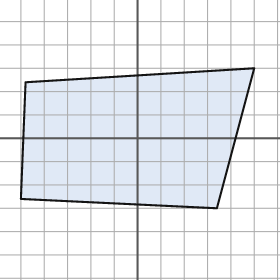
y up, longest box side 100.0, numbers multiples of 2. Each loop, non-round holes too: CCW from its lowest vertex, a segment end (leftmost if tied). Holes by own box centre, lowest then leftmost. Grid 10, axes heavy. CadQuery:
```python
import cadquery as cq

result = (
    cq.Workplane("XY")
    .moveTo(34.0, -30.0)
    .lineTo(50.0, 30.0)
    .lineTo(-48.0, 24.0)
    .lineTo(-50.0, -26.0)
    .close()
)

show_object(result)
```